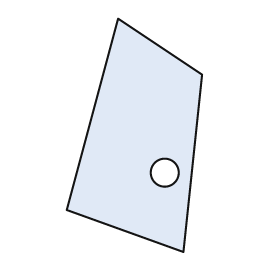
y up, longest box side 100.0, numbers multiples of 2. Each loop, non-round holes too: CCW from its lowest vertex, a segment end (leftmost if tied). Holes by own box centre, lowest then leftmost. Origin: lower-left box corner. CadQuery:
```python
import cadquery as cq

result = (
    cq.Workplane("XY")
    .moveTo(50.0, 0.0)
    .lineTo(58.0, 76.0)
    .lineTo(22.0, 100.0)
    .lineTo(0.0, 18.0)
    .close()
    .moveTo(42.0, 34.0)
    .circle(6.0)
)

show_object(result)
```